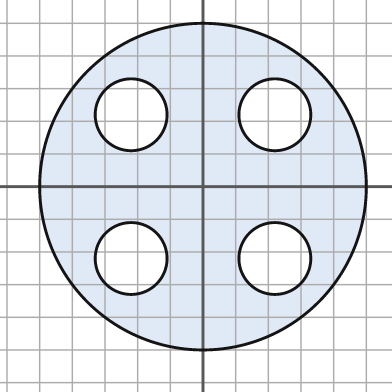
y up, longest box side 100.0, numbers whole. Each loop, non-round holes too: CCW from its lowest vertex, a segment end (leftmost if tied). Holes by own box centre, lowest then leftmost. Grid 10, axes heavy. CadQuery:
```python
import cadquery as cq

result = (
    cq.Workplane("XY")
    .moveTo(0.0, 0.0)
    .circle(50.0)
    .moveTo(-22.0, -22.0)
    .circle(11.0)
    .moveTo(22.0, -22.0)
    .circle(11.0)
    .moveTo(-22.0, 22.0)
    .circle(11.0)
    .moveTo(22.0, 22.0)
    .circle(11.0)
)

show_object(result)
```